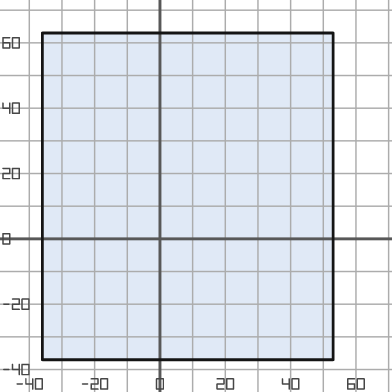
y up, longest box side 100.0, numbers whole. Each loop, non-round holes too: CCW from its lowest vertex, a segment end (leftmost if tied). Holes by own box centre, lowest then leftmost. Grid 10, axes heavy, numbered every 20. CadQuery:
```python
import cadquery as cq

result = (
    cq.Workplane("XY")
    .moveTo(-36.0, -37.0)
    .lineTo(53.0, -37.0)
    .lineTo(53.0, 63.0)
    .lineTo(-36.0, 63.0)
    .close()
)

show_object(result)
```